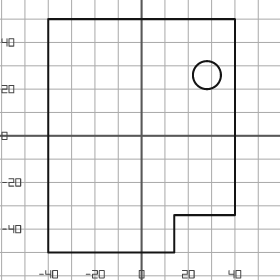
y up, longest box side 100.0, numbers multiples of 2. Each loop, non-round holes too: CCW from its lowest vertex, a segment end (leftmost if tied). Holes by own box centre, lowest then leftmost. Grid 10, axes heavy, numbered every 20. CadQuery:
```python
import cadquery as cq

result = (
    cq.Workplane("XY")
    .moveTo(-40.0, -50.0)
    .lineTo(14.0, -50.0)
    .lineTo(14.0, -34.0)
    .lineTo(40.0, -34.0)
    .lineTo(40.0, 50.0)
    .lineTo(-40.0, 50.0)
    .close()
    .moveTo(28.0, 26.0)
    .circle(6.0)
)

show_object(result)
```